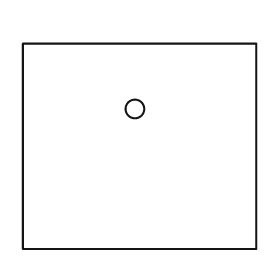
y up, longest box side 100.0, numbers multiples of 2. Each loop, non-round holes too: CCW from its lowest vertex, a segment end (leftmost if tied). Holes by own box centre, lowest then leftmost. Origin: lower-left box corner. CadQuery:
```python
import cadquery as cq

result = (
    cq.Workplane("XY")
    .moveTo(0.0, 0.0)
    .lineTo(100.0, 0.0)
    .lineTo(100.0, 88.0)
    .lineTo(0.0, 88.0)
    .close()
    .moveTo(48.0, 60.0)
    .circle(4.0)
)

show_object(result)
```